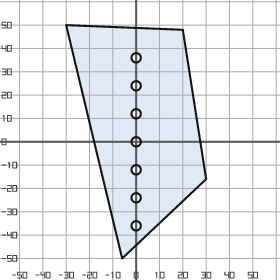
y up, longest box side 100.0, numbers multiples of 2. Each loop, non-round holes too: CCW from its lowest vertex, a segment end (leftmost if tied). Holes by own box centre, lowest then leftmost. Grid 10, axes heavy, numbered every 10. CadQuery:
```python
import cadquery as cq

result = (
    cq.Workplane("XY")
    .moveTo(-6.0, -50.0)
    .lineTo(30.0, -16.0)
    .lineTo(20.0, 48.0)
    .lineTo(-30.0, 50.0)
    .close()
    .moveTo(0.0, -36.0)
    .circle(2.0)
    .moveTo(0.0, -24.0)
    .circle(2.0)
    .moveTo(0.0, -12.0)
    .circle(2.0)
    .moveTo(0.0, 0.0)
    .circle(2.0)
    .moveTo(0.0, 12.0)
    .circle(2.0)
    .moveTo(0.0, 24.0)
    .circle(2.0)
    .moveTo(0.0, 36.0)
    .circle(2.0)
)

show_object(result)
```